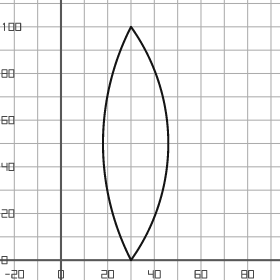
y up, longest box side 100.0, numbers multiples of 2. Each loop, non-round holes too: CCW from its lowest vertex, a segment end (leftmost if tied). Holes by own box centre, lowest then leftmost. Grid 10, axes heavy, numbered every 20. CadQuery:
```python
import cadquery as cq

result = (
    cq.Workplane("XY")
    .moveTo(30.0, 0.0)
    .threePointArc((46.0, 50.0), (30.0, 100.0))
    .threePointArc((18.0, 50.0), (30.0, 0.0))
    .close()
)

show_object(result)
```